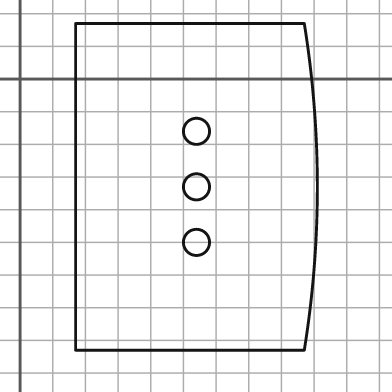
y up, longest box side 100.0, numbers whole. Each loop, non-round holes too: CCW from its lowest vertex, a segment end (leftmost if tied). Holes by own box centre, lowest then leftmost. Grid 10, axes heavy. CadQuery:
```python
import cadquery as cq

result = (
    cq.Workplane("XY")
    .moveTo(17.0, -83.0)
    .lineTo(87.0, -83.0)
    .threePointArc((91.0, -33.0), (87.0, 17.0))
    .lineTo(17.0, 17.0)
    .close()
    .moveTo(54.0, -50.0)
    .circle(4.0)
    .moveTo(54.0, -33.0)
    .circle(4.0)
    .moveTo(54.0, -16.0)
    .circle(4.0)
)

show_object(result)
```